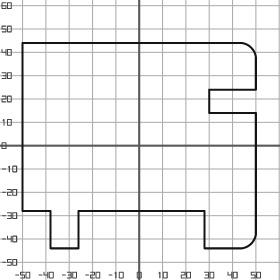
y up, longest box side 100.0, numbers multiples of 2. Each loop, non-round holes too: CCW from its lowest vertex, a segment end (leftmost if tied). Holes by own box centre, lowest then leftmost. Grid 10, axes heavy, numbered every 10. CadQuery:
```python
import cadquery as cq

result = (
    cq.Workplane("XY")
    .moveTo(-38.0, -44.0)
    .lineTo(-26.0, -44.0)
    .lineTo(-26.0, -28.0)
    .lineTo(28.0, -28.0)
    .lineTo(28.0, -44.0)
    .lineTo(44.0, -44.0)
    .threePointArc((48.0, -42.0), (50.0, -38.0))
    .lineTo(50.0, 14.0)
    .lineTo(30.0, 14.0)
    .lineTo(30.0, 24.0)
    .lineTo(50.0, 24.0)
    .lineTo(50.0, 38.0)
    .threePointArc((48.0, 42.0), (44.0, 44.0))
    .lineTo(-50.0, 44.0)
    .lineTo(-50.0, -28.0)
    .lineTo(-38.0, -28.0)
    .close()
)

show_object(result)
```